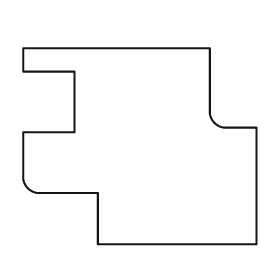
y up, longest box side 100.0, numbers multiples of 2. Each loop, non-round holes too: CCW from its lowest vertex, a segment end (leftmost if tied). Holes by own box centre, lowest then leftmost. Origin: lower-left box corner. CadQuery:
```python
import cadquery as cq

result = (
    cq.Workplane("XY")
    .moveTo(32.0, 0.0)
    .lineTo(100.0, 0.0)
    .lineTo(100.0, 50.0)
    .lineTo(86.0, 50.0)
    .threePointArc((82.0, 52.0), (80.0, 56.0))
    .lineTo(80.0, 84.0)
    .lineTo(0.0, 84.0)
    .lineTo(0.0, 74.0)
    .lineTo(22.0, 74.0)
    .lineTo(22.0, 48.0)
    .lineTo(0.0, 48.0)
    .lineTo(0.0, 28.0)
    .threePointArc((2.0, 24.0), (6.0, 22.0))
    .lineTo(32.0, 22.0)
    .close()
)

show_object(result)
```